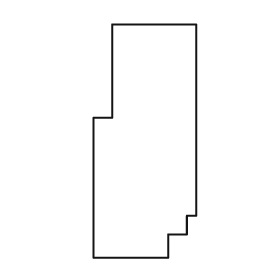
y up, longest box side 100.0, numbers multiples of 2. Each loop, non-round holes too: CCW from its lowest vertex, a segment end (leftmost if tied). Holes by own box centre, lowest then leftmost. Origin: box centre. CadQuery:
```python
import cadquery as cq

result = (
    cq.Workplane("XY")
    .moveTo(-22.0, -50.0)
    .lineTo(10.0, -50.0)
    .lineTo(10.0, -40.0)
    .lineTo(18.0, -40.0)
    .lineTo(18.0, -32.0)
    .lineTo(22.0, -32.0)
    .lineTo(22.0, 50.0)
    .lineTo(-14.0, 50.0)
    .lineTo(-14.0, 10.0)
    .lineTo(-22.0, 10.0)
    .close()
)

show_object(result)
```